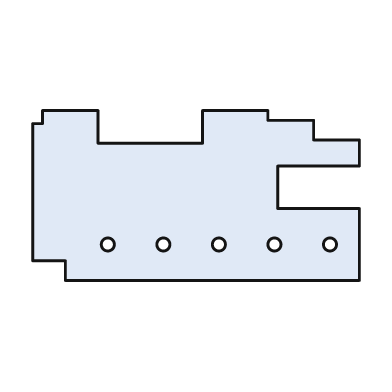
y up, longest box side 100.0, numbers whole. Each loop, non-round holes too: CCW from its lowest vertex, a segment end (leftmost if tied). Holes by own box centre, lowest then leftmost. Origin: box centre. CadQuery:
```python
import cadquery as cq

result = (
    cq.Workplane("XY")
    .moveTo(-40.0, -26.0)
    .lineTo(50.0, -26.0)
    .lineTo(50.0, -4.0)
    .lineTo(25.0, -4.0)
    .lineTo(25.0, 9.0)
    .lineTo(50.0, 9.0)
    .lineTo(50.0, 17.0)
    .lineTo(36.0, 17.0)
    .lineTo(36.0, 23.0)
    .lineTo(22.0, 23.0)
    .lineTo(22.0, 26.0)
    .lineTo(2.0, 26.0)
    .lineTo(2.0, 16.0)
    .lineTo(-30.0, 16.0)
    .lineTo(-30.0, 26.0)
    .lineTo(-47.0, 26.0)
    .lineTo(-47.0, 22.0)
    .lineTo(-50.0, 22.0)
    .lineTo(-50.0, -20.0)
    .lineTo(-40.0, -20.0)
    .close()
    .moveTo(-27.0, -15.0)
    .circle(2.0)
    .moveTo(-10.0, -15.0)
    .circle(2.0)
    .moveTo(7.0, -15.0)
    .circle(2.0)
    .moveTo(24.0, -15.0)
    .circle(2.0)
    .moveTo(41.0, -15.0)
    .circle(2.0)
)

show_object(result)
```